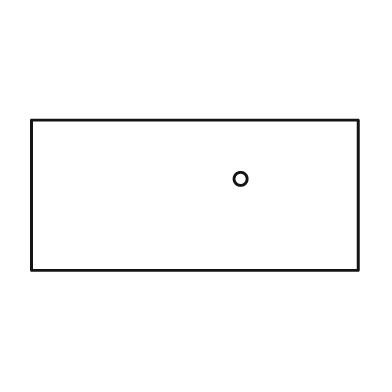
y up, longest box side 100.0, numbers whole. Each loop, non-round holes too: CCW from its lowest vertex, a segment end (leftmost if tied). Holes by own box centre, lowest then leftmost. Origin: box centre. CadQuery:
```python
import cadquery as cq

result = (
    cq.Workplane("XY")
    .moveTo(-50.0, -23.0)
    .lineTo(50.0, -23.0)
    .lineTo(50.0, 23.0)
    .lineTo(-50.0, 23.0)
    .close()
    .moveTo(14.0, 5.0)
    .circle(2.0)
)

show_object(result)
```